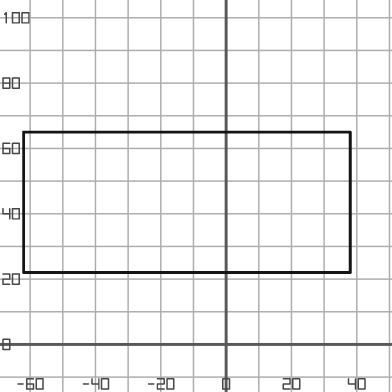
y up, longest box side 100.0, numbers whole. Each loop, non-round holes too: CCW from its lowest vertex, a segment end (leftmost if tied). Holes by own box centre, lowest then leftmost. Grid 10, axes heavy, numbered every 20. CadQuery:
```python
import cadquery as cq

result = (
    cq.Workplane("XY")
    .moveTo(-62.0, 22.0)
    .lineTo(38.0, 22.0)
    .lineTo(38.0, 65.0)
    .lineTo(-62.0, 65.0)
    .close()
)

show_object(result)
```